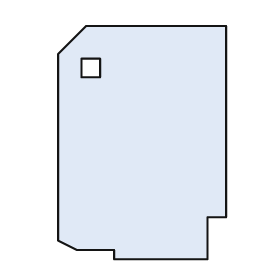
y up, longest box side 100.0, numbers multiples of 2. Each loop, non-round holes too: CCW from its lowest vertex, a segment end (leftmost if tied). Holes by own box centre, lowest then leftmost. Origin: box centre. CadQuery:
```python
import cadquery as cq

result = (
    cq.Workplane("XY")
    .moveTo(-12.0, -50.0)
    .lineTo(28.0, -50.0)
    .lineTo(28.0, -32.0)
    .lineTo(36.0, -32.0)
    .lineTo(36.0, 50.0)
    .lineTo(-24.0, 50.0)
    .lineTo(-36.0, 38.0)
    .lineTo(-36.0, -42.0)
    .lineTo(-28.0, -46.0)
    .lineTo(-12.0, -46.0)
    .close()
    .moveTo(-26.0, 28.0)
    .lineTo(-18.0, 28.0)
    .lineTo(-18.0, 36.0)
    .lineTo(-26.0, 36.0)
    .close()
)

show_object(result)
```